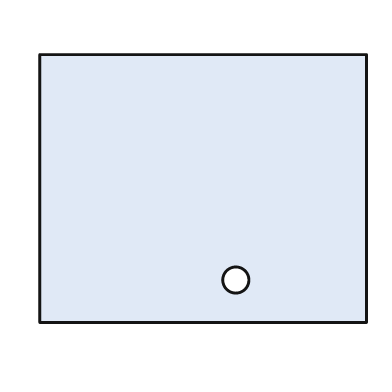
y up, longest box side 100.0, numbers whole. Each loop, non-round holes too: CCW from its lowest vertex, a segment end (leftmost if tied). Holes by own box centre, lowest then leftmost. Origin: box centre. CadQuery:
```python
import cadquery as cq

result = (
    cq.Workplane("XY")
    .moveTo(-50.0, -41.0)
    .lineTo(50.0, -41.0)
    .lineTo(50.0, 41.0)
    .lineTo(-50.0, 41.0)
    .close()
    .moveTo(10.0, -28.0)
    .circle(4.0)
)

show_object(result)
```